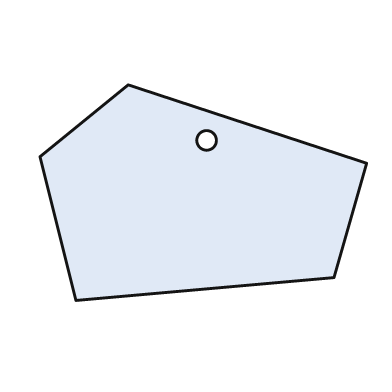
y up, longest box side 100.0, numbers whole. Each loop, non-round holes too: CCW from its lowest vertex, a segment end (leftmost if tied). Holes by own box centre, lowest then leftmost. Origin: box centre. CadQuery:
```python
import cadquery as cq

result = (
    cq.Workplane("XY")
    .moveTo(-39.0, -33.0)
    .lineTo(40.0, -26.0)
    .lineTo(50.0, 9.0)
    .lineTo(-23.0, 33.0)
    .lineTo(-50.0, 11.0)
    .close()
    .moveTo(1.0, 16.0)
    .circle(3.0)
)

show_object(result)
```